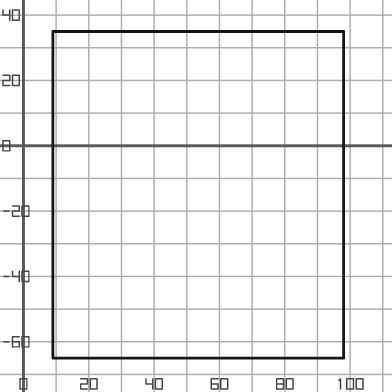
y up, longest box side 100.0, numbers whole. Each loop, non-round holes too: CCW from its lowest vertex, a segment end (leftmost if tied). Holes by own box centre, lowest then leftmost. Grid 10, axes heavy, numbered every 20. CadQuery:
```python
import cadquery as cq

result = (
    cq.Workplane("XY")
    .moveTo(9.0, -65.0)
    .lineTo(98.0, -65.0)
    .lineTo(98.0, 35.0)
    .lineTo(9.0, 35.0)
    .close()
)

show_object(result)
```